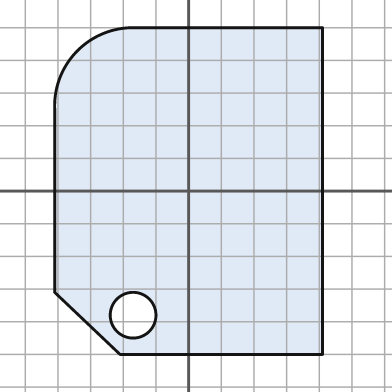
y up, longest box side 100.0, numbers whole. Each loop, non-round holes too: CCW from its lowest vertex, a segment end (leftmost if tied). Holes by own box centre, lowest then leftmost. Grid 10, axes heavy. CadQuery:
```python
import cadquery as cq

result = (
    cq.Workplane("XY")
    .moveTo(-21.0, -50.0)
    .lineTo(41.0, -50.0)
    .lineTo(41.0, 50.0)
    .lineTo(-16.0, 50.0)
    .threePointArc((-34.0, 43.0), (-41.0, 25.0))
    .lineTo(-41.0, -31.0)
    .close()
    .moveTo(-17.0, -38.0)
    .circle(7.0)
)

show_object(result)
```